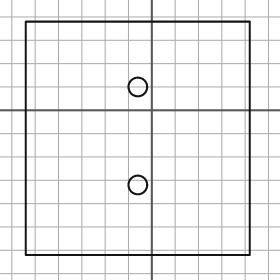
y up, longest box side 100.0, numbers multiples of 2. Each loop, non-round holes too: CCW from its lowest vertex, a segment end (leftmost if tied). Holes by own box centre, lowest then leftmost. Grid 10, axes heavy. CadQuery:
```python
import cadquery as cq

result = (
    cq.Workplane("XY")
    .moveTo(-54.0, -62.0)
    .lineTo(42.0, -62.0)
    .lineTo(42.0, 38.0)
    .lineTo(-54.0, 38.0)
    .close()
    .moveTo(-6.0, -32.0)
    .circle(4.0)
    .moveTo(-6.0, 10.0)
    .circle(4.0)
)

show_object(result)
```